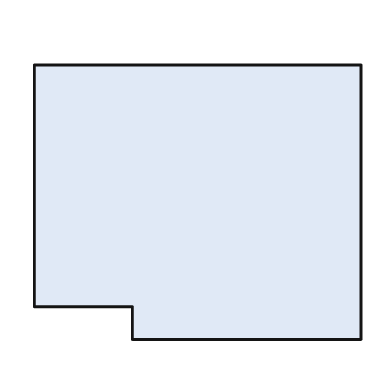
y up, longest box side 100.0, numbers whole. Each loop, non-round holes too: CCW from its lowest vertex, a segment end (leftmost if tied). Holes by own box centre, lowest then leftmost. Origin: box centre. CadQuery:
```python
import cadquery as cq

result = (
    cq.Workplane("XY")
    .moveTo(-20.0, -42.0)
    .lineTo(50.0, -42.0)
    .lineTo(50.0, 42.0)
    .lineTo(-50.0, 42.0)
    .lineTo(-50.0, -32.0)
    .lineTo(-20.0, -32.0)
    .close()
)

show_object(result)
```